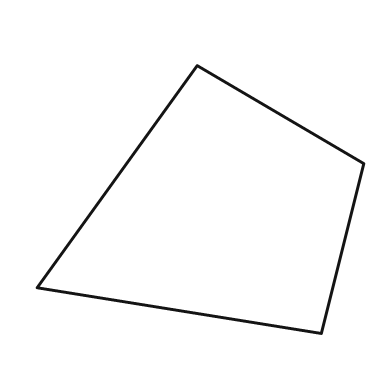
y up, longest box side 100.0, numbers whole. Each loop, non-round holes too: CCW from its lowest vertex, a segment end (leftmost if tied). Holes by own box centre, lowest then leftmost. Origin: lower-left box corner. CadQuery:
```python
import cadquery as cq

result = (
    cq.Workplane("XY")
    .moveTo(87.0, 0.0)
    .lineTo(100.0, 52.0)
    .lineTo(49.0, 82.0)
    .lineTo(0.0, 14.0)
    .close()
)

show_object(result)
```